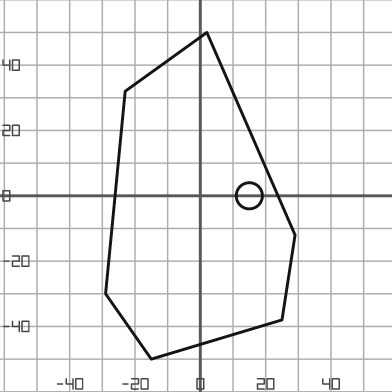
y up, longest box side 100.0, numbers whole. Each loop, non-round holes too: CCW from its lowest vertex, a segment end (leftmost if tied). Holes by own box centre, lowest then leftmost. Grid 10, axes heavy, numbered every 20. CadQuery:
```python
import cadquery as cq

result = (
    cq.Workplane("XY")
    .moveTo(-15.0, -50.0)
    .lineTo(25.0, -38.0)
    .lineTo(29.0, -12.0)
    .lineTo(2.0, 50.0)
    .lineTo(-23.0, 32.0)
    .lineTo(-29.0, -30.0)
    .close()
    .moveTo(15.0, 0.0)
    .circle(4.0)
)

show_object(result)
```